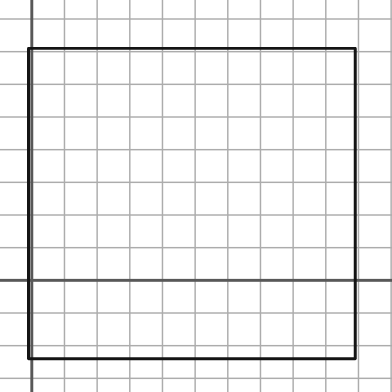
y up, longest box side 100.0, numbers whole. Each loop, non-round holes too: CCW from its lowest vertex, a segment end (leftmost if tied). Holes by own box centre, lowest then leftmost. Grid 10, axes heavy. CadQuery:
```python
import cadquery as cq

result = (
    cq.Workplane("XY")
    .moveTo(-1.0, -24.0)
    .lineTo(99.0, -24.0)
    .lineTo(99.0, 71.0)
    .lineTo(-1.0, 71.0)
    .close()
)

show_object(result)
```